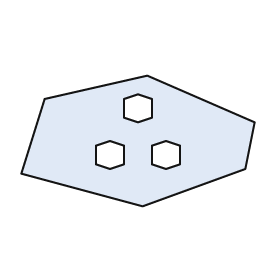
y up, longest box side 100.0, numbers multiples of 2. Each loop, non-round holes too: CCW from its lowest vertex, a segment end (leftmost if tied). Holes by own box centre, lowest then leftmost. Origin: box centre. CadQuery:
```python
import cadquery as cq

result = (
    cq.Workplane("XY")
    .moveTo(2.0, -28.0)
    .lineTo(46.0, -12.0)
    .lineTo(50.0, 8.0)
    .lineTo(4.0, 28.0)
    .lineTo(-40.0, 18.0)
    .lineTo(-50.0, -14.0)
    .close()
    .moveTo(-12.0, -12.0)
    .lineTo(-6.0, -10.0)
    .lineTo(-6.0, -2.0)
    .lineTo(-12.0, 0.0)
    .lineTo(-18.0, -2.0)
    .lineTo(-18.0, -10.0)
    .close()
    .moveTo(12.0, -12.0)
    .lineTo(18.0, -10.0)
    .lineTo(18.0, -2.0)
    .lineTo(12.0, 0.0)
    .lineTo(6.0, -2.0)
    .lineTo(6.0, -10.0)
    .close()
    .moveTo(0.0, 8.0)
    .lineTo(6.0, 10.0)
    .lineTo(6.0, 18.0)
    .lineTo(0.0, 20.0)
    .lineTo(-6.0, 18.0)
    .lineTo(-6.0, 10.0)
    .close()
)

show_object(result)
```